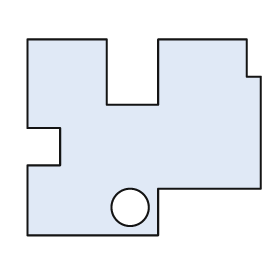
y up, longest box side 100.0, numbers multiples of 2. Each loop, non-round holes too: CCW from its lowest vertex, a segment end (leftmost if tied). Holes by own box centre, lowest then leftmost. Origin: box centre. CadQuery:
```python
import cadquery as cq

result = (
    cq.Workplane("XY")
    .moveTo(-50.0, -42.0)
    .lineTo(6.0, -42.0)
    .lineTo(6.0, -22.0)
    .lineTo(50.0, -22.0)
    .lineTo(50.0, 26.0)
    .lineTo(44.0, 26.0)
    .lineTo(44.0, 42.0)
    .lineTo(6.0, 42.0)
    .lineTo(6.0, 14.0)
    .lineTo(-16.0, 14.0)
    .lineTo(-16.0, 42.0)
    .lineTo(-50.0, 42.0)
    .lineTo(-50.0, 4.0)
    .lineTo(-36.0, 4.0)
    .lineTo(-36.0, -12.0)
    .lineTo(-50.0, -12.0)
    .close()
    .moveTo(-6.0, -30.0)
    .circle(8.0)
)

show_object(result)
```